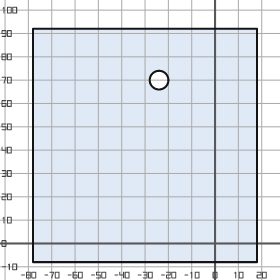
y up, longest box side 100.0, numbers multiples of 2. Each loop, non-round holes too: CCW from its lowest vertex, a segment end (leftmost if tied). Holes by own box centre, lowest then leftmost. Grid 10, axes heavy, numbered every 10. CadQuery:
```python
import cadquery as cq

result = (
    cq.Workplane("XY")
    .moveTo(-78.0, -8.0)
    .lineTo(18.0, -8.0)
    .lineTo(18.0, 92.0)
    .lineTo(-78.0, 92.0)
    .close()
    .moveTo(-24.0, 70.0)
    .circle(4.0)
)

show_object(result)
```